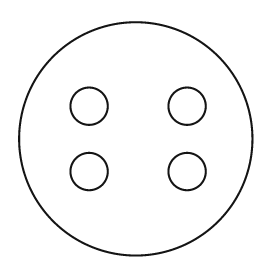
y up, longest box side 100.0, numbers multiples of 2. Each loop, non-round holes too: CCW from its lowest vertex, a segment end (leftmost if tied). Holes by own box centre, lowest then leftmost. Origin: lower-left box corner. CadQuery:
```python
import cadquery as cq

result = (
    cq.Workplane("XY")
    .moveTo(50.0, 50.0)
    .circle(50.0)
    .moveTo(30.0, 36.0)
    .circle(8.0)
    .moveTo(72.0, 36.0)
    .circle(8.0)
    .moveTo(30.0, 64.0)
    .circle(8.0)
    .moveTo(72.0, 64.0)
    .circle(8.0)
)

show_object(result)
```